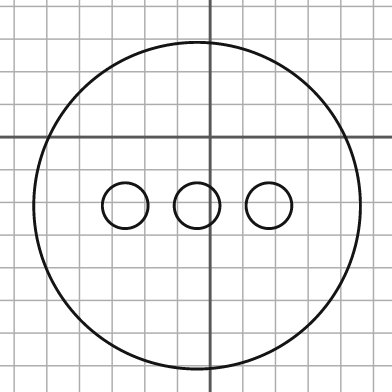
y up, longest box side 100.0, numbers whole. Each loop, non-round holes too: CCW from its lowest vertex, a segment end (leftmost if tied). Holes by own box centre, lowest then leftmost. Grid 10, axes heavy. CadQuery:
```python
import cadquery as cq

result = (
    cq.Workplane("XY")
    .moveTo(-4.0, -21.0)
    .circle(50.0)
    .moveTo(-26.0, -21.0)
    .circle(7.0)
    .moveTo(-4.0, -21.0)
    .circle(7.0)
    .moveTo(18.0, -21.0)
    .circle(7.0)
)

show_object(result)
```